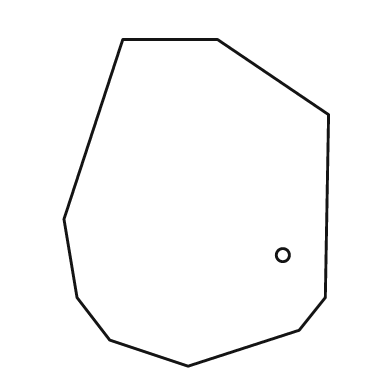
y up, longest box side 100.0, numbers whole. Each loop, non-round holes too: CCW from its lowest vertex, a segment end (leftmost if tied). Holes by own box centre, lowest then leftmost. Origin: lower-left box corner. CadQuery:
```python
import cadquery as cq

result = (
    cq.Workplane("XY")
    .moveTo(38.0, 0.0)
    .lineTo(72.0, 11.0)
    .lineTo(80.0, 21.0)
    .lineTo(81.0, 77.0)
    .lineTo(47.0, 100.0)
    .lineTo(18.0, 100.0)
    .lineTo(0.0, 45.0)
    .lineTo(4.0, 21.0)
    .lineTo(14.0, 8.0)
    .close()
    .moveTo(67.0, 34.0)
    .circle(2.0)
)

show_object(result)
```